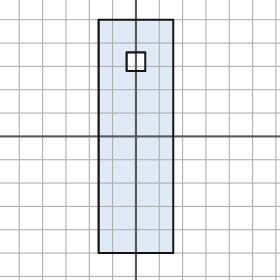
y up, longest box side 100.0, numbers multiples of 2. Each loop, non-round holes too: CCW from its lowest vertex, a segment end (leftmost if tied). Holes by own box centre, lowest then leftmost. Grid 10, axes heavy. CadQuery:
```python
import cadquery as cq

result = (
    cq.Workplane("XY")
    .moveTo(-16.0, -50.0)
    .lineTo(16.0, -50.0)
    .lineTo(16.0, 50.0)
    .lineTo(-16.0, 50.0)
    .close()
    .moveTo(-4.0, 28.0)
    .lineTo(4.0, 28.0)
    .lineTo(4.0, 36.0)
    .lineTo(-4.0, 36.0)
    .close()
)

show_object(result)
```